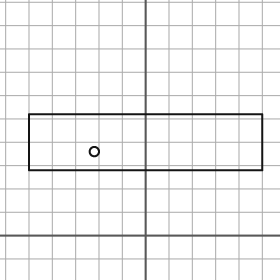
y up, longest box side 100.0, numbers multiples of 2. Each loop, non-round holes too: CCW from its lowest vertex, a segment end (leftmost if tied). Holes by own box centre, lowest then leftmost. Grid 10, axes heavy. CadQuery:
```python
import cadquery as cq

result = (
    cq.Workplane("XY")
    .moveTo(-50.0, 28.0)
    .lineTo(50.0, 28.0)
    .lineTo(50.0, 52.0)
    .lineTo(-50.0, 52.0)
    .close()
    .moveTo(-22.0, 36.0)
    .circle(2.0)
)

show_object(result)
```